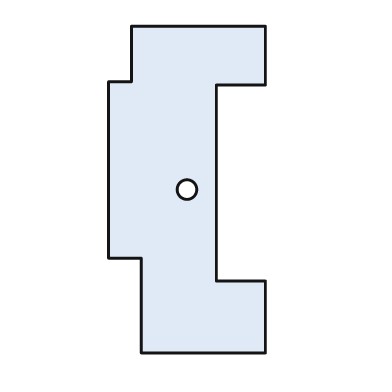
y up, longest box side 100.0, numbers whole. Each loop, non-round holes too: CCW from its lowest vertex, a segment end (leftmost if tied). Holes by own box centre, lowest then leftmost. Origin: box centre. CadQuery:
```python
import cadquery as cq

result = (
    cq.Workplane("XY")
    .moveTo(-14.0, -50.0)
    .lineTo(24.0, -50.0)
    .lineTo(24.0, -28.0)
    .lineTo(9.0, -28.0)
    .lineTo(9.0, 32.0)
    .lineTo(24.0, 32.0)
    .lineTo(24.0, 50.0)
    .lineTo(-17.0, 50.0)
    .lineTo(-17.0, 33.0)
    .lineTo(-24.0, 33.0)
    .lineTo(-24.0, -21.0)
    .lineTo(-14.0, -21.0)
    .close()
    .moveTo(0.0, 0.0)
    .circle(3.0)
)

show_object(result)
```